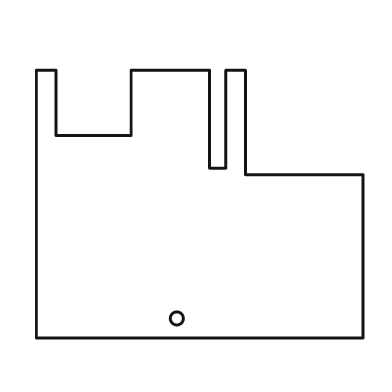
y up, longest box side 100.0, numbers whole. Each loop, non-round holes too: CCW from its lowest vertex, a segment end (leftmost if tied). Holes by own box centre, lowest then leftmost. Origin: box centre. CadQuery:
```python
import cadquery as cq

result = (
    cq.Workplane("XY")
    .moveTo(-50.0, -41.0)
    .lineTo(50.0, -41.0)
    .lineTo(50.0, 9.0)
    .lineTo(14.0, 9.0)
    .lineTo(14.0, 41.0)
    .lineTo(8.0, 41.0)
    .lineTo(8.0, 11.0)
    .lineTo(3.0, 11.0)
    .lineTo(3.0, 41.0)
    .lineTo(-21.0, 41.0)
    .lineTo(-21.0, 21.0)
    .lineTo(-44.0, 21.0)
    .lineTo(-44.0, 41.0)
    .lineTo(-50.0, 41.0)
    .close()
    .moveTo(-7.0, -35.0)
    .circle(2.0)
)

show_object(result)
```